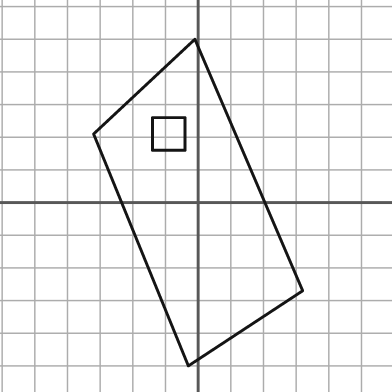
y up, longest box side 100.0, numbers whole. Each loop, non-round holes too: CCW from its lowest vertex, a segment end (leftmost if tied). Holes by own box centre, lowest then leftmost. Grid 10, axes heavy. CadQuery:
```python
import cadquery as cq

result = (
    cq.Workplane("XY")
    .moveTo(-3.0, -50.0)
    .lineTo(32.0, -27.0)
    .lineTo(-1.0, 50.0)
    .lineTo(-32.0, 21.0)
    .close()
    .moveTo(-14.0, 16.0)
    .lineTo(-4.0, 16.0)
    .lineTo(-4.0, 26.0)
    .lineTo(-14.0, 26.0)
    .close()
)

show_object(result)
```